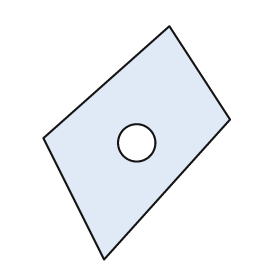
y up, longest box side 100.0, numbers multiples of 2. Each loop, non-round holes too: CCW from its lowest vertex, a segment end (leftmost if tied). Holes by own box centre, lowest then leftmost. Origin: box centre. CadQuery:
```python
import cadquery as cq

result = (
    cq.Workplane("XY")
    .moveTo(-14.0, -50.0)
    .lineTo(40.0, 10.0)
    .lineTo(14.0, 50.0)
    .lineTo(-40.0, 2.0)
    .close()
    .moveTo(0.0, 0.0)
    .circle(8.0)
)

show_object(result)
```